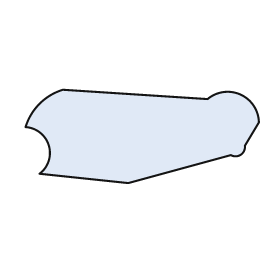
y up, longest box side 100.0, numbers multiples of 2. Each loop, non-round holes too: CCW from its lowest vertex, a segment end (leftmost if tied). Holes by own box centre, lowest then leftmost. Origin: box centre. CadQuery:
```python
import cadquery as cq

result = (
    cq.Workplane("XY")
    .moveTo(-6.0, -20.0)
    .lineTo(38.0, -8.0)
    .threePointArc((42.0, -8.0), (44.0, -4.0))
    .lineTo(50.0, 6.0)
    .threePointArc((42.0, 18.0), (28.0, 16.0))
    .lineTo(-34.0, 20.0)
    .threePointArc((-44.0, 14.0), (-50.0, 4.0))
    .threePointArc((-40.0, -4.0), (-44.0, -16.0))
    .close()
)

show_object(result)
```